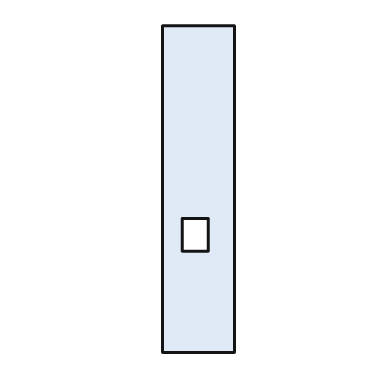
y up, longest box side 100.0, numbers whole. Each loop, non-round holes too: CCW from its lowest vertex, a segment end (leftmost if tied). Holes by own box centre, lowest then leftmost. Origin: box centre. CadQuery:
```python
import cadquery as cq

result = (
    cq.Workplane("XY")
    .moveTo(-11.0, -50.0)
    .lineTo(11.0, -50.0)
    .lineTo(11.0, 50.0)
    .lineTo(-11.0, 50.0)
    .close()
    .moveTo(-5.0, -19.0)
    .lineTo(3.0, -19.0)
    .lineTo(3.0, -9.0)
    .lineTo(-5.0, -9.0)
    .close()
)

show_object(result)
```